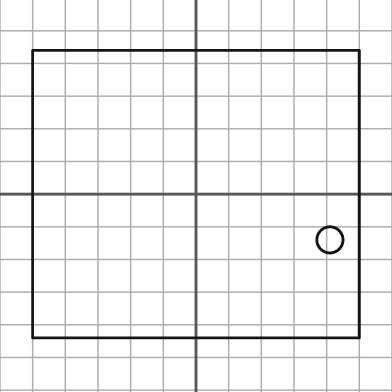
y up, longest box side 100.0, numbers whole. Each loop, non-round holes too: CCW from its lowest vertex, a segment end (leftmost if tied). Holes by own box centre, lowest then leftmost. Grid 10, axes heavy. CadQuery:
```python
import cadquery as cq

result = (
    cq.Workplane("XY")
    .moveTo(-50.0, -44.0)
    .lineTo(50.0, -44.0)
    .lineTo(50.0, 44.0)
    .lineTo(-50.0, 44.0)
    .close()
    .moveTo(41.0, -14.0)
    .circle(4.0)
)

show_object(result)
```